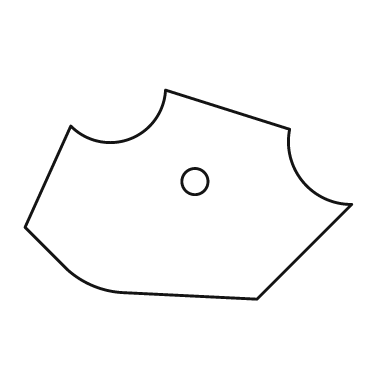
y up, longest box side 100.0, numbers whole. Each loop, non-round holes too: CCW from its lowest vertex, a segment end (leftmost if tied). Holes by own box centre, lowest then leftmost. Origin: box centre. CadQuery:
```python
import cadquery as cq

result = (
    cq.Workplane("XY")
    .moveTo(21.0, -32.0)
    .lineTo(50.0, -3.0)
    .threePointArc((35.0, 4.0), (31.0, 20.0))
    .lineTo(-7.0, 32.0)
    .threePointArc((-18.0, 17.0), (-36.0, 21.0))
    .lineTo(-50.0, -10.0)
    .lineTo(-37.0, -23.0)
    .threePointArc((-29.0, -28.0), (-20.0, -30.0))
    .close()
    .moveTo(2.0, 4.0)
    .circle(4.0)
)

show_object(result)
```